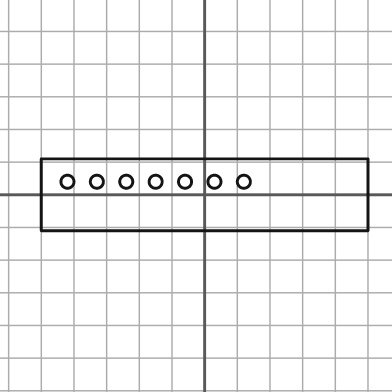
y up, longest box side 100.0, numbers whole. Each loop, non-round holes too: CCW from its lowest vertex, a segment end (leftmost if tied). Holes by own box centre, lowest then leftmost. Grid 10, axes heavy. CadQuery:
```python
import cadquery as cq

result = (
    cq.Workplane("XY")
    .moveTo(-50.0, -11.0)
    .lineTo(50.0, -11.0)
    .lineTo(50.0, 11.0)
    .lineTo(-50.0, 11.0)
    .close()
    .moveTo(-42.0, 4.0)
    .circle(2.0)
    .moveTo(-33.0, 4.0)
    .circle(2.0)
    .moveTo(-24.0, 4.0)
    .circle(2.0)
    .moveTo(-15.0, 4.0)
    .circle(2.0)
    .moveTo(-6.0, 4.0)
    .circle(2.0)
    .moveTo(3.0, 4.0)
    .circle(2.0)
    .moveTo(12.0, 4.0)
    .circle(2.0)
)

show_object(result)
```